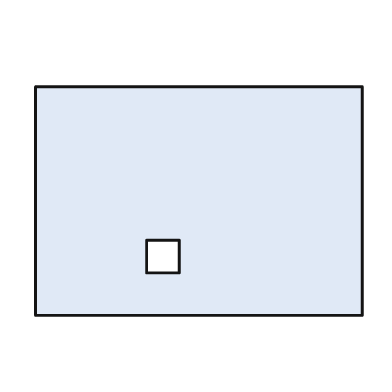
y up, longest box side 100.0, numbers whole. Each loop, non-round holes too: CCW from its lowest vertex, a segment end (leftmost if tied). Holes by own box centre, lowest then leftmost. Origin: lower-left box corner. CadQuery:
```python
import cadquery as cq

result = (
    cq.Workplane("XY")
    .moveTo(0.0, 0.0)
    .lineTo(100.0, 0.0)
    .lineTo(100.0, 70.0)
    .lineTo(0.0, 70.0)
    .close()
    .moveTo(34.0, 13.0)
    .lineTo(44.0, 13.0)
    .lineTo(44.0, 23.0)
    .lineTo(34.0, 23.0)
    .close()
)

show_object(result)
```